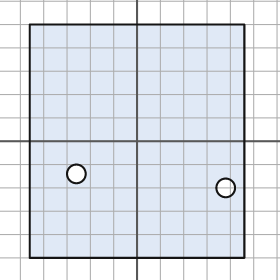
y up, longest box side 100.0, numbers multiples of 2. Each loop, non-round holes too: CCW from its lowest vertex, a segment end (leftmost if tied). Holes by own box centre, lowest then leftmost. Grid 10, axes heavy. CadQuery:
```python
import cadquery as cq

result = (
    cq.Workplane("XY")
    .moveTo(-46.0, -50.0)
    .lineTo(46.0, -50.0)
    .lineTo(46.0, 50.0)
    .lineTo(-46.0, 50.0)
    .close()
    .moveTo(38.0, -20.0)
    .circle(4.0)
    .moveTo(-26.0, -14.0)
    .circle(4.0)
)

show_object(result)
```